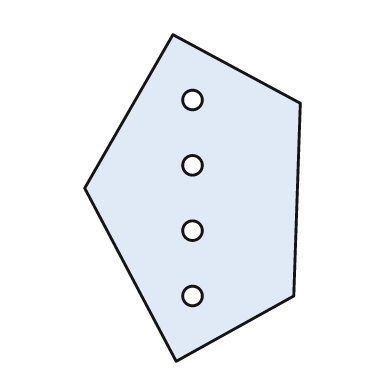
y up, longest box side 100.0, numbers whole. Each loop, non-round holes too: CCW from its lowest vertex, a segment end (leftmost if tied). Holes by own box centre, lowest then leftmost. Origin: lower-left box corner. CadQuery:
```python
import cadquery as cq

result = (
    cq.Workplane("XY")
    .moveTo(28.0, 0.0)
    .lineTo(64.0, 20.0)
    .lineTo(66.0, 79.0)
    .lineTo(27.0, 100.0)
    .lineTo(0.0, 53.0)
    .close()
    .moveTo(33.0, 20.0)
    .circle(3.0)
    .moveTo(33.0, 40.0)
    .circle(3.0)
    .moveTo(33.0, 60.0)
    .circle(3.0)
    .moveTo(33.0, 80.0)
    .circle(3.0)
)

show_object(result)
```